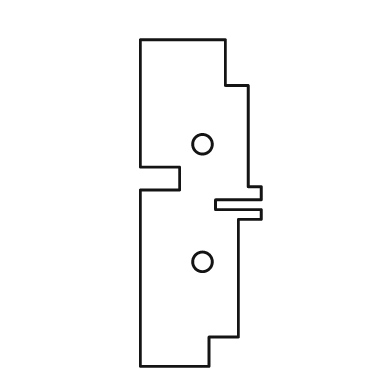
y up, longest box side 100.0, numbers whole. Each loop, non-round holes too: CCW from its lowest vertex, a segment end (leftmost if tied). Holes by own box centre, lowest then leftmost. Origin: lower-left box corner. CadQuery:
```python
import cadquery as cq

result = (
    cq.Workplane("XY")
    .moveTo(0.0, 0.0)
    .lineTo(21.0, 0.0)
    .lineTo(21.0, 9.0)
    .lineTo(30.0, 9.0)
    .lineTo(30.0, 45.0)
    .lineTo(37.0, 45.0)
    .lineTo(37.0, 48.0)
    .lineTo(23.0, 48.0)
    .lineTo(23.0, 51.0)
    .lineTo(37.0, 51.0)
    .lineTo(37.0, 55.0)
    .lineTo(33.0, 55.0)
    .lineTo(33.0, 86.0)
    .lineTo(26.0, 86.0)
    .lineTo(26.0, 100.0)
    .lineTo(0.0, 100.0)
    .lineTo(0.0, 61.0)
    .lineTo(12.0, 61.0)
    .lineTo(12.0, 54.0)
    .lineTo(0.0, 54.0)
    .close()
    .moveTo(19.0, 32.0)
    .circle(3.0)
    .moveTo(19.0, 68.0)
    .circle(3.0)
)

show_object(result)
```